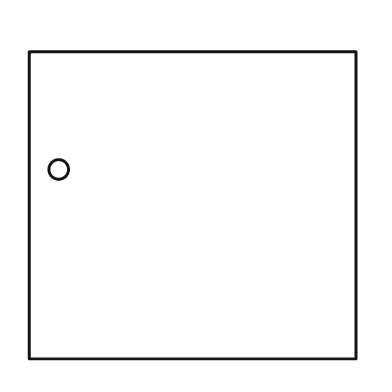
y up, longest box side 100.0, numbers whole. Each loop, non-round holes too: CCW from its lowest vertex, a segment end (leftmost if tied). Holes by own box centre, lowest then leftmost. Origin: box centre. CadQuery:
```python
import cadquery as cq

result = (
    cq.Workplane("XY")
    .moveTo(-50.0, -47.0)
    .lineTo(50.0, -47.0)
    .lineTo(50.0, 47.0)
    .lineTo(-50.0, 47.0)
    .close()
    .moveTo(-41.0, 11.0)
    .circle(3.0)
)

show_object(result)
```